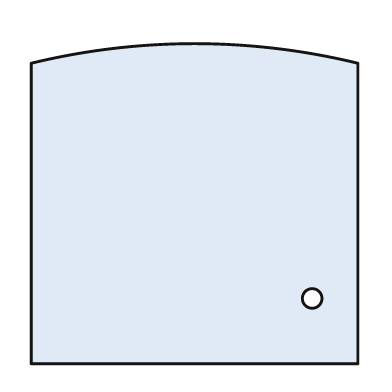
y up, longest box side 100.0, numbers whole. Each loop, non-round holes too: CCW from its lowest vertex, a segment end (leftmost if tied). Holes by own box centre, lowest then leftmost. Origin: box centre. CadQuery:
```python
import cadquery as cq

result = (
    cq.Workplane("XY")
    .moveTo(-50.0, -49.0)
    .lineTo(50.0, -49.0)
    .lineTo(50.0, 43.0)
    .threePointArc((0.0, 49.0), (-50.0, 43.0))
    .close()
    .moveTo(36.0, -29.0)
    .circle(3.0)
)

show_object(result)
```